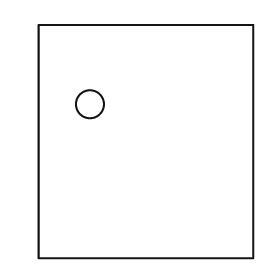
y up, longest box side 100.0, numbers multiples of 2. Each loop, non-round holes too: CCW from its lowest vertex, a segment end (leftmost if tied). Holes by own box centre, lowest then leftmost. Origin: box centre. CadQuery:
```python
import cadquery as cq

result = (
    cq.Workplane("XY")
    .moveTo(-46.0, -50.0)
    .lineTo(46.0, -50.0)
    .lineTo(46.0, 50.0)
    .lineTo(-46.0, 50.0)
    .close()
    .moveTo(-24.0, 16.0)
    .circle(6.0)
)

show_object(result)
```